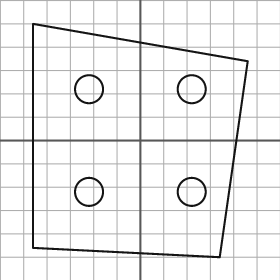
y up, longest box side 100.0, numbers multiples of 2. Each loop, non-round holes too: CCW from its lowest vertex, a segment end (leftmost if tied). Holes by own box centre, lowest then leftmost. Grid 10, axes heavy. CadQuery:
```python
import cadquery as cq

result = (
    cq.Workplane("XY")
    .moveTo(34.0, -50.0)
    .lineTo(46.0, 34.0)
    .lineTo(-46.0, 50.0)
    .lineTo(-46.0, -46.0)
    .close()
    .moveTo(-22.0, -22.0)
    .circle(6.0)
    .moveTo(22.0, -22.0)
    .circle(6.0)
    .moveTo(-22.0, 22.0)
    .circle(6.0)
    .moveTo(22.0, 22.0)
    .circle(6.0)
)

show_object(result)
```